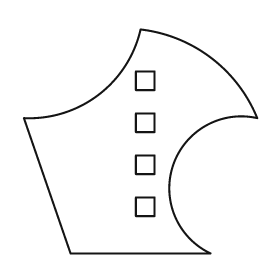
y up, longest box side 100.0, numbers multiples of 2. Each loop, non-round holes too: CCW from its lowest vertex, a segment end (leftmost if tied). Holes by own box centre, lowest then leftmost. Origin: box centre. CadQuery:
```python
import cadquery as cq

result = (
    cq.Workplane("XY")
    .moveTo(-30.0, -48.0)
    .lineTo(30.0, -48.0)
    .threePointArc((14.0, -10.0), (50.0, 10.0))
    .threePointArc((30.0, 36.0), (0.0, 48.0))
    .threePointArc((-18.0, 20.0), (-50.0, 10.0))
    .close()
    .moveTo(-2.0, -32.0)
    .lineTo(6.0, -32.0)
    .lineTo(6.0, -24.0)
    .lineTo(-2.0, -24.0)
    .close()
    .moveTo(-2.0, -14.0)
    .lineTo(6.0, -14.0)
    .lineTo(6.0, -6.0)
    .lineTo(-2.0, -6.0)
    .close()
    .moveTo(-2.0, 4.0)
    .lineTo(6.0, 4.0)
    .lineTo(6.0, 12.0)
    .lineTo(-2.0, 12.0)
    .close()
    .moveTo(-2.0, 22.0)
    .lineTo(6.0, 22.0)
    .lineTo(6.0, 30.0)
    .lineTo(-2.0, 30.0)
    .close()
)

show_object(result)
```